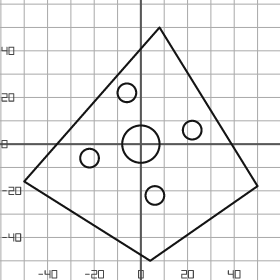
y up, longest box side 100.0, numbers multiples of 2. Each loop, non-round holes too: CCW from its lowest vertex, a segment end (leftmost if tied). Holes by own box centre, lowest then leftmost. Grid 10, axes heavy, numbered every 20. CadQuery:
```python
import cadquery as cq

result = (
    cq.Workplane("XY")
    .moveTo(4.0, -50.0)
    .lineTo(50.0, -18.0)
    .lineTo(8.0, 50.0)
    .lineTo(-50.0, -16.0)
    .close()
    .moveTo(6.0, -22.0)
    .circle(4.0)
    .moveTo(-22.0, -6.0)
    .circle(4.0)
    .moveTo(0.0, 0.0)
    .circle(8.0)
    .moveTo(22.0, 6.0)
    .circle(4.0)
    .moveTo(-6.0, 22.0)
    .circle(4.0)
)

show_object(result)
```